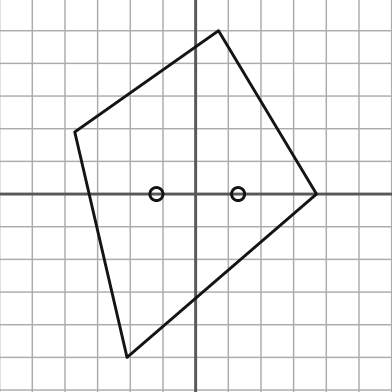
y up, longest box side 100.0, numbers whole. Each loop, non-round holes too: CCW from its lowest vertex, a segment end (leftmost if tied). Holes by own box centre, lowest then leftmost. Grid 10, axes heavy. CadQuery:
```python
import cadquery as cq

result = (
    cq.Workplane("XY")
    .moveTo(-21.0, -50.0)
    .lineTo(37.0, 0.0)
    .lineTo(7.0, 50.0)
    .lineTo(-37.0, 19.0)
    .close()
    .moveTo(-12.0, 0.0)
    .circle(2.0)
    .moveTo(13.0, 0.0)
    .circle(2.0)
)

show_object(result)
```